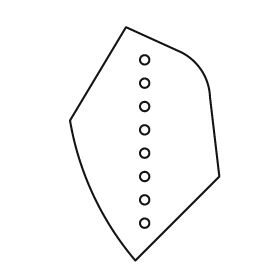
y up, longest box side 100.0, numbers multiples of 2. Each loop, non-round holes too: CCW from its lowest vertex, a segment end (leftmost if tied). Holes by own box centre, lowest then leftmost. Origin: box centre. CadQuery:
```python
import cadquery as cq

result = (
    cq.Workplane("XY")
    .moveTo(-4.0, -50.0)
    .lineTo(32.0, -14.0)
    .lineTo(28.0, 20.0)
    .threePointArc((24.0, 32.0), (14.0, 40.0))
    .lineTo(-8.0, 50.0)
    .lineTo(-32.0, 10.0)
    .threePointArc((-22.0, -22.0), (-4.0, -50.0))
    .close()
    .moveTo(0.0, -34.0)
    .circle(2.0)
    .moveTo(0.0, -24.0)
    .circle(2.0)
    .moveTo(0.0, -14.0)
    .circle(2.0)
    .moveTo(0.0, -4.0)
    .circle(2.0)
    .moveTo(0.0, 6.0)
    .circle(2.0)
    .moveTo(0.0, 16.0)
    .circle(2.0)
    .moveTo(0.0, 26.0)
    .circle(2.0)
    .moveTo(0.0, 36.0)
    .circle(2.0)
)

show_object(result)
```